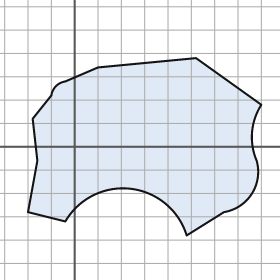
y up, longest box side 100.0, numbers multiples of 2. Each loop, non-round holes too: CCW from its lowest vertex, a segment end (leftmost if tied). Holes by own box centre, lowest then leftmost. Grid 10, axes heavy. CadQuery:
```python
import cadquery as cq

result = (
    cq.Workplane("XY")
    .moveTo(48.0, -38.0)
    .lineTo(64.0, -28.0)
    .threePointArc((76.0, -20.0), (78.0, -6.0))
    .threePointArc((76.0, 6.0), (80.0, 18.0))
    .lineTo(52.0, 38.0)
    .lineTo(10.0, 34.0)
    .lineTo(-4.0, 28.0)
    .threePointArc((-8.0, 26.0), (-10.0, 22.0))
    .lineTo(-18.0, 12.0)
    .lineTo(-16.0, -6.0)
    .lineTo(-20.0, -28.0)
    .lineTo(-4.0, -32.0)
    .threePointArc((24.0, -18.0), (48.0, -38.0))
    .close()
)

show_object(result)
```